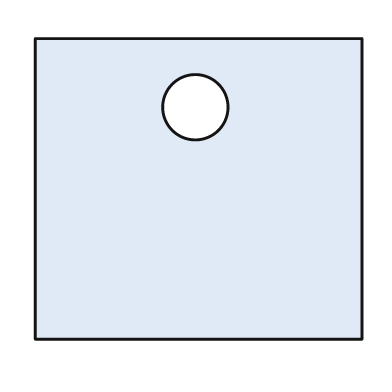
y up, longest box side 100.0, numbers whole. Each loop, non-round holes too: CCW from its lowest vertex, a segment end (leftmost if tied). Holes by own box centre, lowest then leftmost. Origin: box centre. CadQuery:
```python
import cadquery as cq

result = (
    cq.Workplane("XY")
    .moveTo(-50.0, -46.0)
    .lineTo(50.0, -46.0)
    .lineTo(50.0, 46.0)
    .lineTo(-50.0, 46.0)
    .close()
    .moveTo(-1.0, 25.0)
    .circle(10.0)
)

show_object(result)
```